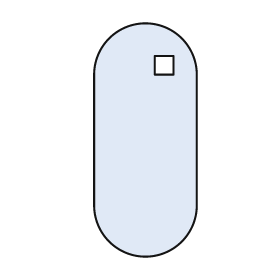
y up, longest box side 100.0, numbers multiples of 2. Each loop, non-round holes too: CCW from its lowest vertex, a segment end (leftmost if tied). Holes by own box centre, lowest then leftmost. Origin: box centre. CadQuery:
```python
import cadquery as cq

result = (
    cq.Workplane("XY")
    .moveTo(-22.0, -28.0)
    .threePointArc((0.0, -50.0), (22.0, -28.0))
    .lineTo(22.0, 28.0)
    .threePointArc((0.0, 50.0), (-22.0, 28.0))
    .close()
    .moveTo(4.0, 28.0)
    .lineTo(12.0, 28.0)
    .lineTo(12.0, 36.0)
    .lineTo(4.0, 36.0)
    .close()
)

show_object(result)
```